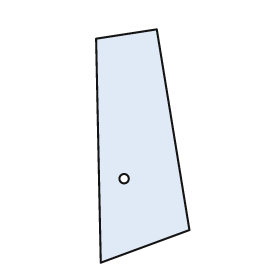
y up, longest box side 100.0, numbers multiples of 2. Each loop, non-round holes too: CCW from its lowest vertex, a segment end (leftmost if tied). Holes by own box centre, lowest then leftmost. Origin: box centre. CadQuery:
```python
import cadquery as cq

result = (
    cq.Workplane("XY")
    .moveTo(-18.0, -50.0)
    .lineTo(20.0, -36.0)
    .lineTo(6.0, 50.0)
    .lineTo(-20.0, 46.0)
    .close()
    .moveTo(-8.0, -14.0)
    .circle(2.0)
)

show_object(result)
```